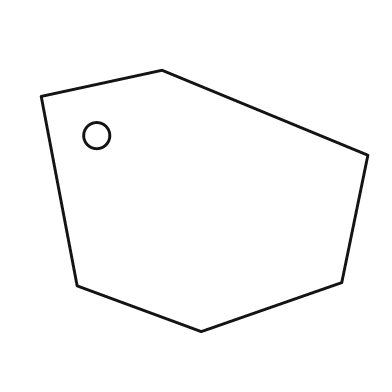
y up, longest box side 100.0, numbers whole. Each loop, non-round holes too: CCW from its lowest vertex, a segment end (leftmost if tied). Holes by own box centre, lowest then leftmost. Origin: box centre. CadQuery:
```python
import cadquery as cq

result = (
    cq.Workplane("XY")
    .moveTo(-1.0, -40.0)
    .lineTo(42.0, -25.0)
    .lineTo(50.0, 14.0)
    .lineTo(-13.0, 40.0)
    .lineTo(-50.0, 32.0)
    .lineTo(-39.0, -26.0)
    .close()
    .moveTo(-33.0, 20.0)
    .circle(4.0)
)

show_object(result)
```